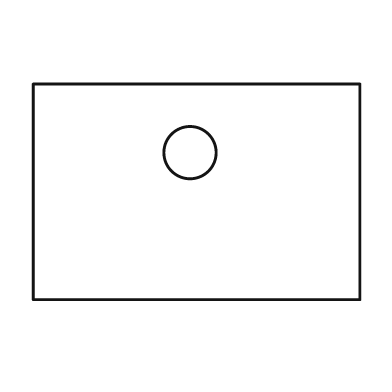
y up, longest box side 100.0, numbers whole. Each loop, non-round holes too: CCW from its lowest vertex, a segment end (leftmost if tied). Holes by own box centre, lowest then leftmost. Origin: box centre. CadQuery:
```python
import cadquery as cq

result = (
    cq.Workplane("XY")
    .moveTo(-50.0, -33.0)
    .lineTo(50.0, -33.0)
    .lineTo(50.0, 33.0)
    .lineTo(-50.0, 33.0)
    .close()
    .moveTo(-2.0, 12.0)
    .circle(8.0)
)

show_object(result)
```